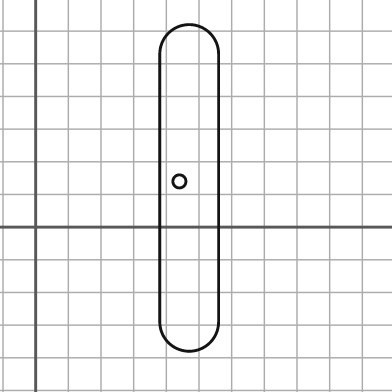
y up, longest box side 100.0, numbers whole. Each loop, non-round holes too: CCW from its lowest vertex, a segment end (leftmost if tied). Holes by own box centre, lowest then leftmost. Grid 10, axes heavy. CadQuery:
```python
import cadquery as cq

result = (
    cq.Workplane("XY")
    .moveTo(38.0, -29.0)
    .threePointArc((47.0, -38.0), (56.0, -29.0))
    .lineTo(56.0, 53.0)
    .threePointArc((47.0, 62.0), (38.0, 53.0))
    .close()
    .moveTo(44.0, 14.0)
    .circle(2.0)
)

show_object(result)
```